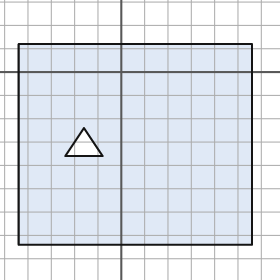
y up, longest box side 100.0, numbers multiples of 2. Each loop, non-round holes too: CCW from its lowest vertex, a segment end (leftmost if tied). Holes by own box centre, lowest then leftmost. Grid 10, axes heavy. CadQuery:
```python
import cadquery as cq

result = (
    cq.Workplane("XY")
    .moveTo(-44.0, -74.0)
    .lineTo(56.0, -74.0)
    .lineTo(56.0, 12.0)
    .lineTo(-44.0, 12.0)
    .close()
    .moveTo(-24.0, -36.0)
    .lineTo(-8.0, -36.0)
    .lineTo(-16.0, -24.0)
    .close()
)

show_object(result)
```